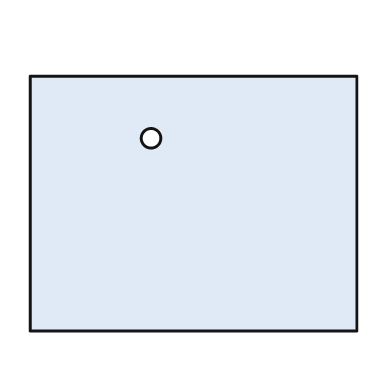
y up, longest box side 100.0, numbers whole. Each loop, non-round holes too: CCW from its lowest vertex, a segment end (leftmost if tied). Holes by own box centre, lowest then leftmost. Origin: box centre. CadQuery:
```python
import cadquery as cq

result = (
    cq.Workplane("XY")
    .moveTo(-50.0, -39.0)
    .lineTo(50.0, -39.0)
    .lineTo(50.0, 39.0)
    .lineTo(-50.0, 39.0)
    .close()
    .moveTo(-13.0, 20.0)
    .circle(3.0)
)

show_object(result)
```